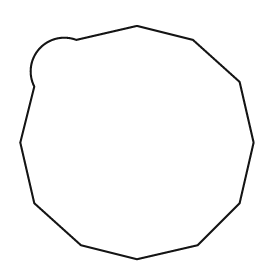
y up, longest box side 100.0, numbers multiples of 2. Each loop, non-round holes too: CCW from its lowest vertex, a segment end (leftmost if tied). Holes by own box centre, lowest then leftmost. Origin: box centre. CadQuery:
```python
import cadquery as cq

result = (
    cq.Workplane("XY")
    .moveTo(0.0, -50.0)
    .lineTo(26.0, -44.0)
    .lineTo(44.0, -26.0)
    .lineTo(50.0, 0.0)
    .lineTo(44.0, 26.0)
    .lineTo(24.0, 44.0)
    .lineTo(0.0, 50.0)
    .lineTo(-26.0, 44.0)
    .threePointArc((-42.0, 40.0), (-44.0, 24.0))
    .lineTo(-50.0, 0.0)
    .lineTo(-44.0, -26.0)
    .lineTo(-24.0, -44.0)
    .close()
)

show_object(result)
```